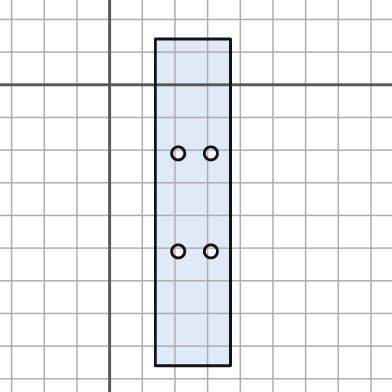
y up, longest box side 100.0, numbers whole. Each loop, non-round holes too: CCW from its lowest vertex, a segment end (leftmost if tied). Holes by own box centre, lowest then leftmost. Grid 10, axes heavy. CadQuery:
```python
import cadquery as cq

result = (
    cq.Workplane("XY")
    .moveTo(14.0, -86.0)
    .lineTo(37.0, -86.0)
    .lineTo(37.0, 14.0)
    .lineTo(14.0, 14.0)
    .close()
    .moveTo(21.0, -51.0)
    .circle(2.0)
    .moveTo(31.0, -51.0)
    .circle(2.0)
    .moveTo(21.0, -21.0)
    .circle(2.0)
    .moveTo(31.0, -21.0)
    .circle(2.0)
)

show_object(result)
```